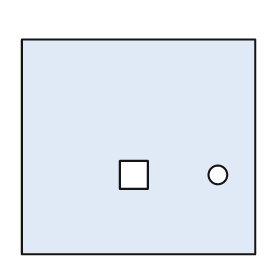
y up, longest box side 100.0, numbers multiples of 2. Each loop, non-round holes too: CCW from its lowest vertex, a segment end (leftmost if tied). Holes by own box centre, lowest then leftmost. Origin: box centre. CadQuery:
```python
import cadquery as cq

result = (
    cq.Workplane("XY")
    .moveTo(-50.0, -46.0)
    .lineTo(50.0, -46.0)
    .lineTo(50.0, 46.0)
    .lineTo(-50.0, 46.0)
    .close()
    .moveTo(-8.0, -18.0)
    .lineTo(4.0, -18.0)
    .lineTo(4.0, -6.0)
    .lineTo(-8.0, -6.0)
    .close()
    .moveTo(34.0, -12.0)
    .circle(4.0)
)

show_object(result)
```